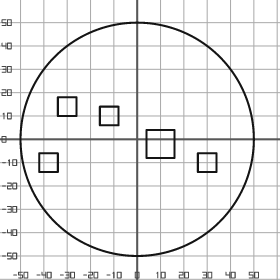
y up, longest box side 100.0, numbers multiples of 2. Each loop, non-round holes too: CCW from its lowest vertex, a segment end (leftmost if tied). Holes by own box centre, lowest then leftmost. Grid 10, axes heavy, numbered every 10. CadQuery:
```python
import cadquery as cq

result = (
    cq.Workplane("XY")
    .moveTo(0.0, 0.0)
    .circle(50.0)
    .moveTo(-42.0, -14.0)
    .lineTo(-34.0, -14.0)
    .lineTo(-34.0, -6.0)
    .lineTo(-42.0, -6.0)
    .close()
    .moveTo(26.0, -14.0)
    .lineTo(34.0, -14.0)
    .lineTo(34.0, -6.0)
    .lineTo(26.0, -6.0)
    .close()
    .moveTo(4.0, -8.0)
    .lineTo(16.0, -8.0)
    .lineTo(16.0, 4.0)
    .lineTo(4.0, 4.0)
    .close()
    .moveTo(-16.0, 6.0)
    .lineTo(-8.0, 6.0)
    .lineTo(-8.0, 14.0)
    .lineTo(-16.0, 14.0)
    .close()
    .moveTo(-34.0, 10.0)
    .lineTo(-26.0, 10.0)
    .lineTo(-26.0, 18.0)
    .lineTo(-34.0, 18.0)
    .close()
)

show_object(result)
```